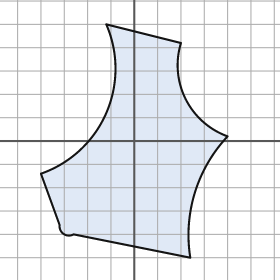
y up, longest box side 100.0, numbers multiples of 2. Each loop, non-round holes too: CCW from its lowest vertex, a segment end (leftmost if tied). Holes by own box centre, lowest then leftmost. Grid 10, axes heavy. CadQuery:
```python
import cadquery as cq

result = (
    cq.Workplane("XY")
    .moveTo(24.0, -50.0)
    .threePointArc((26.0, -22.0), (40.0, 2.0))
    .threePointArc((22.0, 18.0), (20.0, 42.0))
    .lineTo(-12.0, 50.0)
    .threePointArc((-12.0, 12.0), (-40.0, -14.0))
    .lineTo(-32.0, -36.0)
    .threePointArc((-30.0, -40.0), (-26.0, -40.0))
    .close()
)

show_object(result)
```